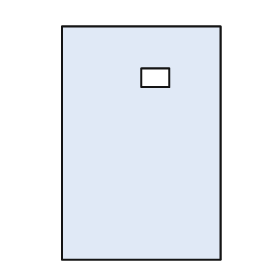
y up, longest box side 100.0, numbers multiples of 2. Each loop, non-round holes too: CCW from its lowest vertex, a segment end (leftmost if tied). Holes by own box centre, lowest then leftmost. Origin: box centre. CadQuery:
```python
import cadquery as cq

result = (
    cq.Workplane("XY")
    .moveTo(-34.0, -50.0)
    .lineTo(34.0, -50.0)
    .lineTo(34.0, 50.0)
    .lineTo(-34.0, 50.0)
    .close()
    .moveTo(0.0, 24.0)
    .lineTo(12.0, 24.0)
    .lineTo(12.0, 32.0)
    .lineTo(0.0, 32.0)
    .close()
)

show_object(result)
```